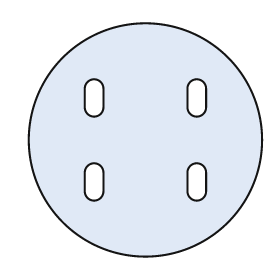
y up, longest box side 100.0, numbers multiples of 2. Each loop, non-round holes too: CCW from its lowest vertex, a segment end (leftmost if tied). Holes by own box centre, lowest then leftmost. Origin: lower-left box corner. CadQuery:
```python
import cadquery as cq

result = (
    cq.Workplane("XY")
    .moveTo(50.0, 50.0)
    .circle(50.0)
    .moveTo(24.0, 28.0)
    .threePointArc((28.0, 24.0), (32.0, 28.0))
    .lineTo(32.0, 36.0)
    .threePointArc((28.0, 40.0), (24.0, 36.0))
    .close()
    .moveTo(68.0, 28.0)
    .threePointArc((72.0, 24.0), (76.0, 28.0))
    .lineTo(76.0, 36.0)
    .threePointArc((72.0, 40.0), (68.0, 36.0))
    .close()
    .moveTo(24.0, 64.0)
    .threePointArc((28.0, 60.0), (32.0, 64.0))
    .lineTo(32.0, 72.0)
    .threePointArc((28.0, 76.0), (24.0, 72.0))
    .close()
    .moveTo(68.0, 64.0)
    .threePointArc((72.0, 60.0), (76.0, 64.0))
    .lineTo(76.0, 72.0)
    .threePointArc((72.0, 76.0), (68.0, 72.0))
    .close()
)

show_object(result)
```